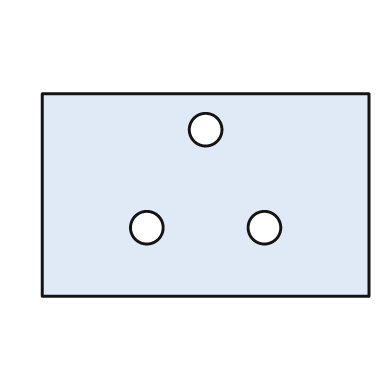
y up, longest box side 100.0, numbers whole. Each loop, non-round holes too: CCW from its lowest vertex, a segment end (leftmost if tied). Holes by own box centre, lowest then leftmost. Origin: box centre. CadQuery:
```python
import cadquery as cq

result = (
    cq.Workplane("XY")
    .moveTo(-50.0, -31.0)
    .lineTo(50.0, -31.0)
    .lineTo(50.0, 31.0)
    .lineTo(-50.0, 31.0)
    .close()
    .moveTo(-18.0, -10.0)
    .circle(5.0)
    .moveTo(18.0, -10.0)
    .circle(5.0)
    .moveTo(0.0, 20.0)
    .circle(5.0)
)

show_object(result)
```